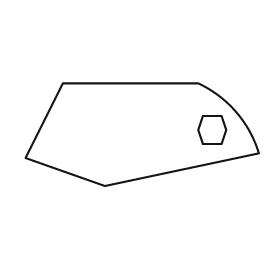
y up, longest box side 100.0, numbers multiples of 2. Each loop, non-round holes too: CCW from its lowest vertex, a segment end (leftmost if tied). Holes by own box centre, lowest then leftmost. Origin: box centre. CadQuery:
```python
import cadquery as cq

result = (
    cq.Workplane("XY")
    .moveTo(-16.0, -22.0)
    .lineTo(50.0, -8.0)
    .threePointArc((40.0, 10.0), (24.0, 22.0))
    .lineTo(-34.0, 22.0)
    .lineTo(-50.0, -10.0)
    .close()
    .moveTo(26.0, -4.0)
    .lineTo(34.0, -4.0)
    .lineTo(36.0, 2.0)
    .lineTo(34.0, 8.0)
    .lineTo(26.0, 8.0)
    .lineTo(24.0, 2.0)
    .close()
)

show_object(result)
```